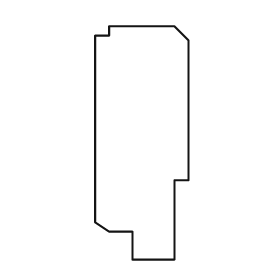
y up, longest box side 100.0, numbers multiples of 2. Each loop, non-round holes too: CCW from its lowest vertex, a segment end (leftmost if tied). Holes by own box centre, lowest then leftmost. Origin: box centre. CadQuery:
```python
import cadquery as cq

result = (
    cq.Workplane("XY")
    .moveTo(-4.0, -50.0)
    .lineTo(14.0, -50.0)
    .lineTo(14.0, -16.0)
    .lineTo(20.0, -16.0)
    .lineTo(20.0, 44.0)
    .lineTo(14.0, 50.0)
    .lineTo(-14.0, 50.0)
    .lineTo(-14.0, 46.0)
    .lineTo(-20.0, 46.0)
    .lineTo(-20.0, -34.0)
    .lineTo(-14.0, -38.0)
    .lineTo(-4.0, -38.0)
    .close()
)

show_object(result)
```